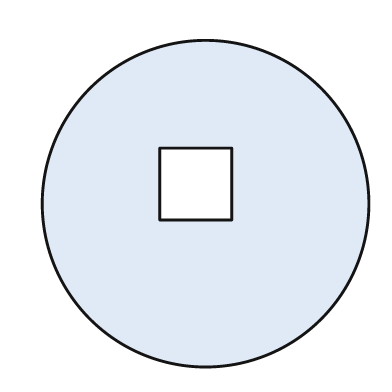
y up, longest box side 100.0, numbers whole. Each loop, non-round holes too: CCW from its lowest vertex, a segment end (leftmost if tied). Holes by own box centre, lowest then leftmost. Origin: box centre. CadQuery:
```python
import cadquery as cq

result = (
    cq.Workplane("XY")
    .moveTo(0.0, 0.0)
    .circle(50.0)
    .moveTo(-14.0, -5.0)
    .lineTo(8.0, -5.0)
    .lineTo(8.0, 17.0)
    .lineTo(-14.0, 17.0)
    .close()
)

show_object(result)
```